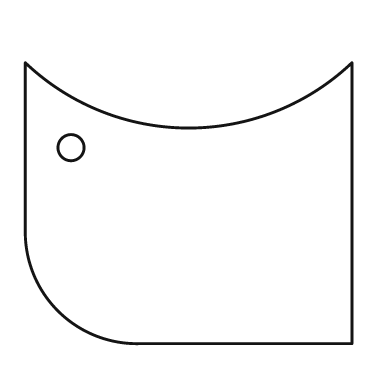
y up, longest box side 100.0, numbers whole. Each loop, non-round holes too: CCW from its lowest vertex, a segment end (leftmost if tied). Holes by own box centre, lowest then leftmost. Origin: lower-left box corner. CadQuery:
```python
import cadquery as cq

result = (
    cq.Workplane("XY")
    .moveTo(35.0, 0.0)
    .lineTo(100.0, 0.0)
    .lineTo(100.0, 86.0)
    .threePointArc((50.0, 66.0), (0.0, 86.0))
    .lineTo(0.0, 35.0)
    .threePointArc((10.0, 10.0), (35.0, 0.0))
    .close()
    .moveTo(14.0, 60.0)
    .circle(4.0)
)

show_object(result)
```